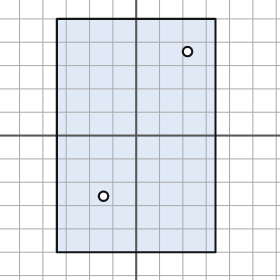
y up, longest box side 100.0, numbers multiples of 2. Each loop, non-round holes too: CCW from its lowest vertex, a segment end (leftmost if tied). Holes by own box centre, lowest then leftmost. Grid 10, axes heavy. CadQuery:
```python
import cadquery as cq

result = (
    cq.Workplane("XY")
    .moveTo(-34.0, -50.0)
    .lineTo(34.0, -50.0)
    .lineTo(34.0, 50.0)
    .lineTo(-34.0, 50.0)
    .close()
    .moveTo(-14.0, -26.0)
    .circle(2.0)
    .moveTo(22.0, 36.0)
    .circle(2.0)
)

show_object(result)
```